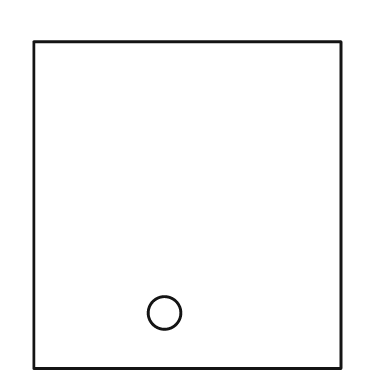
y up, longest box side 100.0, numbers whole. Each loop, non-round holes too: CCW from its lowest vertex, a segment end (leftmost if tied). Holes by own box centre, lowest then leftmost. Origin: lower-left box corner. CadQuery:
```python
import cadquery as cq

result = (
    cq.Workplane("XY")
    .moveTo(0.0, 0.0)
    .lineTo(94.0, 0.0)
    .lineTo(94.0, 100.0)
    .lineTo(0.0, 100.0)
    .close()
    .moveTo(40.0, 17.0)
    .circle(5.0)
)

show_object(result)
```